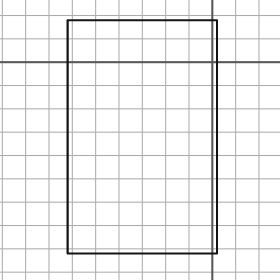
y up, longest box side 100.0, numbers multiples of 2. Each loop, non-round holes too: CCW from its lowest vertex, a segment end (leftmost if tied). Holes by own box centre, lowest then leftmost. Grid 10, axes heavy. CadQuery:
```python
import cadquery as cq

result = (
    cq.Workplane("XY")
    .moveTo(-62.0, -82.0)
    .lineTo(2.0, -82.0)
    .lineTo(2.0, 18.0)
    .lineTo(-62.0, 18.0)
    .close()
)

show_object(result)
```